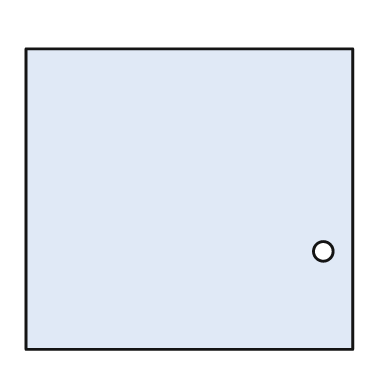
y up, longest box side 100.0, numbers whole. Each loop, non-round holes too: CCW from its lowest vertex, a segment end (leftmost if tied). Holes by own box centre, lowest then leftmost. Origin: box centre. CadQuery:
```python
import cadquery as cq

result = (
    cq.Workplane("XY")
    .moveTo(-50.0, -46.0)
    .lineTo(50.0, -46.0)
    .lineTo(50.0, 46.0)
    .lineTo(-50.0, 46.0)
    .close()
    .moveTo(41.0, -16.0)
    .circle(3.0)
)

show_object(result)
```